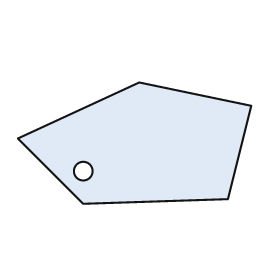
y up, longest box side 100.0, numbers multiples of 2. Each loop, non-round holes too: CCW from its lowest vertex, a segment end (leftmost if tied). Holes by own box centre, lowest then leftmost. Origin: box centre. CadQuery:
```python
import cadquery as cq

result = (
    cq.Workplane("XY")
    .moveTo(-22.0, -26.0)
    .lineTo(40.0, -24.0)
    .lineTo(50.0, 16.0)
    .lineTo(2.0, 26.0)
    .lineTo(-50.0, 2.0)
    .close()
    .moveTo(-22.0, -12.0)
    .circle(4.0)
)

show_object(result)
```